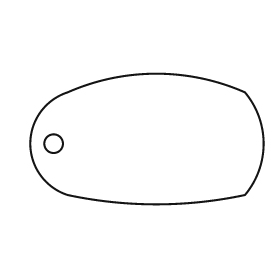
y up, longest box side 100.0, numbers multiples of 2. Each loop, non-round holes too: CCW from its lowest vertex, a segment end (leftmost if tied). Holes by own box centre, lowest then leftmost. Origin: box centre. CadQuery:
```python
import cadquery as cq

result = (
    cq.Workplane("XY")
    .moveTo(-34.0, -24.0)
    .threePointArc((4.0, -28.0), (42.0, -24.0))
    .threePointArc((50.0, -2.0), (42.0, 20.0))
    .threePointArc((4.0, 28.0), (-34.0, 20.0))
    .threePointArc((-50.0, -2.0), (-34.0, -24.0))
    .close()
    .moveTo(-40.0, -2.0)
    .circle(4.0)
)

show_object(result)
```